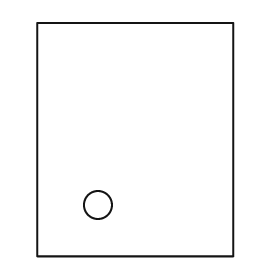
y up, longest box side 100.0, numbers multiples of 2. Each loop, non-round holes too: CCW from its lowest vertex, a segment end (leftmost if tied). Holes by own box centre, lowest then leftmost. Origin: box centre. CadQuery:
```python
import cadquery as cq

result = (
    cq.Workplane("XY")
    .moveTo(-42.0, -50.0)
    .lineTo(42.0, -50.0)
    .lineTo(42.0, 50.0)
    .lineTo(-42.0, 50.0)
    .close()
    .moveTo(-16.0, -28.0)
    .circle(6.0)
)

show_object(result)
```